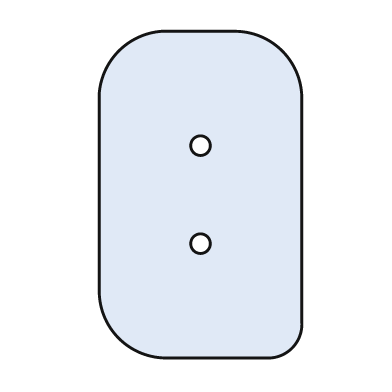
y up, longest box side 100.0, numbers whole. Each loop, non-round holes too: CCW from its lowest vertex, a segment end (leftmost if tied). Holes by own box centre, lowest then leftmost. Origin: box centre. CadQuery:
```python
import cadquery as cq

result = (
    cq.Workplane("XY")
    .moveTo(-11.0, -50.0)
    .lineTo(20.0, -50.0)
    .threePointArc((28.0, -47.0), (31.0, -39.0))
    .lineTo(31.0, 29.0)
    .threePointArc((25.0, 44.0), (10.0, 50.0))
    .lineTo(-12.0, 50.0)
    .threePointArc((-25.0, 44.0), (-31.0, 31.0))
    .lineTo(-31.0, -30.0)
    .threePointArc((-25.0, -44.0), (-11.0, -50.0))
    .close()
    .moveTo(0.0, -15.0)
    .circle(3.0)
    .moveTo(0.0, 15.0)
    .circle(3.0)
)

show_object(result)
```